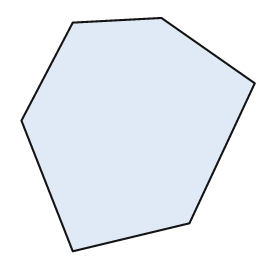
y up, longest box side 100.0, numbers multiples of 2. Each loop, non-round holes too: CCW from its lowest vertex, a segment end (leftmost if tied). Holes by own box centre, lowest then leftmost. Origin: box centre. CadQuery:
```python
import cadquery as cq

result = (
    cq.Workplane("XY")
    .moveTo(-28.0, -50.0)
    .lineTo(22.0, -38.0)
    .lineTo(50.0, 22.0)
    .lineTo(10.0, 50.0)
    .lineTo(-28.0, 48.0)
    .lineTo(-50.0, 6.0)
    .close()
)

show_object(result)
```